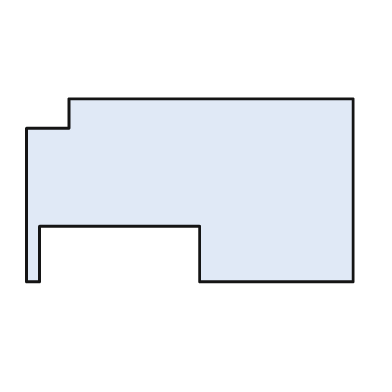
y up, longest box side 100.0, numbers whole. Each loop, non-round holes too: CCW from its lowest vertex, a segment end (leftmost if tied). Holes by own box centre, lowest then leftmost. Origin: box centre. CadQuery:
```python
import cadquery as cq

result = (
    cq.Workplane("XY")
    .moveTo(-50.0, -28.0)
    .lineTo(-46.0, -28.0)
    .lineTo(-46.0, -11.0)
    .lineTo(3.0, -11.0)
    .lineTo(3.0, -28.0)
    .lineTo(50.0, -28.0)
    .lineTo(50.0, 28.0)
    .lineTo(-37.0, 28.0)
    .lineTo(-37.0, 19.0)
    .lineTo(-50.0, 19.0)
    .close()
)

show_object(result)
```